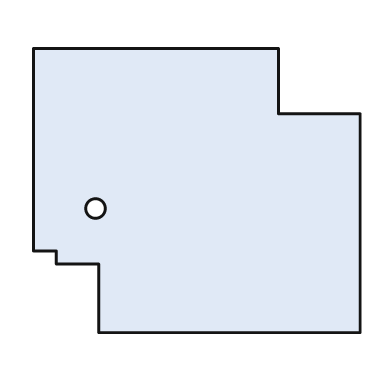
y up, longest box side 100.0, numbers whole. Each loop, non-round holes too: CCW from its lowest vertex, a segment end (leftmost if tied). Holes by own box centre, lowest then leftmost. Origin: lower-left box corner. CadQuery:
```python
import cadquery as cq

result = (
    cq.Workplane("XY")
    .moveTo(20.0, 0.0)
    .lineTo(100.0, 0.0)
    .lineTo(100.0, 67.0)
    .lineTo(75.0, 67.0)
    .lineTo(75.0, 87.0)
    .lineTo(0.0, 87.0)
    .lineTo(0.0, 25.0)
    .lineTo(7.0, 25.0)
    .lineTo(7.0, 21.0)
    .lineTo(20.0, 21.0)
    .close()
    .moveTo(19.0, 38.0)
    .circle(3.0)
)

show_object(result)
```